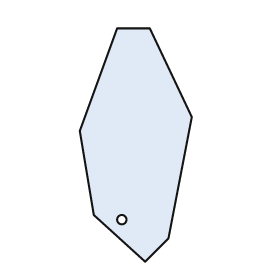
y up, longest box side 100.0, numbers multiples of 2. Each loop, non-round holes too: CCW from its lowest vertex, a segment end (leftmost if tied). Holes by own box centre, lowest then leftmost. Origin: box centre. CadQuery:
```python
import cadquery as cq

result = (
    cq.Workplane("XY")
    .moveTo(4.0, -50.0)
    .lineTo(14.0, -40.0)
    .lineTo(24.0, 12.0)
    .lineTo(6.0, 50.0)
    .lineTo(-8.0, 50.0)
    .lineTo(-24.0, 6.0)
    .lineTo(-18.0, -30.0)
    .close()
    .moveTo(-6.0, -32.0)
    .circle(2.0)
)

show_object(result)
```